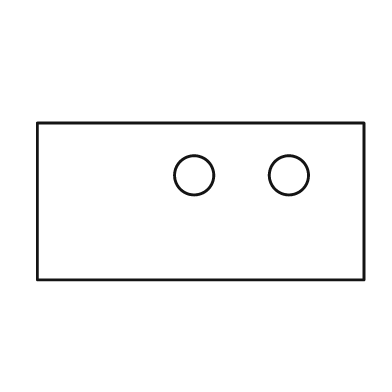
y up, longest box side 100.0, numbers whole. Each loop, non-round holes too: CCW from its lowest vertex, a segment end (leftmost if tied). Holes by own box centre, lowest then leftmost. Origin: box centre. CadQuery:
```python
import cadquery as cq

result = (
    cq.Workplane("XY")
    .moveTo(-50.0, -24.0)
    .lineTo(50.0, -24.0)
    .lineTo(50.0, 24.0)
    .lineTo(-50.0, 24.0)
    .close()
    .moveTo(-2.0, 8.0)
    .circle(6.0)
    .moveTo(27.0, 8.0)
    .circle(6.0)
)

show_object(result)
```